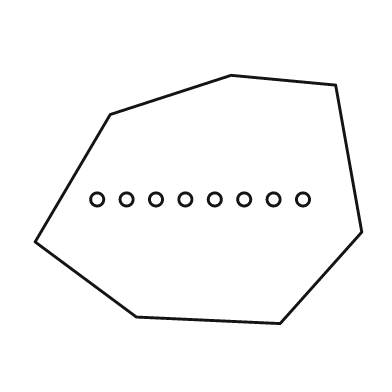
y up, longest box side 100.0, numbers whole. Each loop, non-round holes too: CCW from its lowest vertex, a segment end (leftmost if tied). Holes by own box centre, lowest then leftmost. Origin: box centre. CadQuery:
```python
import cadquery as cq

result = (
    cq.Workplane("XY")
    .moveTo(25.0, -38.0)
    .lineTo(50.0, -10.0)
    .lineTo(42.0, 35.0)
    .lineTo(10.0, 38.0)
    .lineTo(-27.0, 26.0)
    .lineTo(-50.0, -13.0)
    .lineTo(-19.0, -36.0)
    .close()
    .moveTo(-31.0, 0.0)
    .circle(2.0)
    .moveTo(-22.0, 0.0)
    .circle(2.0)
    .moveTo(-13.0, 0.0)
    .circle(2.0)
    .moveTo(-4.0, 0.0)
    .circle(2.0)
    .moveTo(5.0, 0.0)
    .circle(2.0)
    .moveTo(14.0, 0.0)
    .circle(2.0)
    .moveTo(23.0, 0.0)
    .circle(2.0)
    .moveTo(32.0, 0.0)
    .circle(2.0)
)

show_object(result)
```